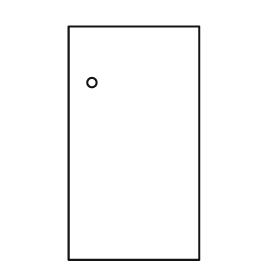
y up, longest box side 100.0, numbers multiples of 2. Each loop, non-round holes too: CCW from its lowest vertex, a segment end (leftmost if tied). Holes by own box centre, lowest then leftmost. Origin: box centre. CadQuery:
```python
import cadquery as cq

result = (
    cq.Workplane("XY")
    .moveTo(-28.0, -50.0)
    .lineTo(28.0, -50.0)
    .lineTo(28.0, 50.0)
    .lineTo(-28.0, 50.0)
    .close()
    .moveTo(-18.0, 26.0)
    .circle(2.0)
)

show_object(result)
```